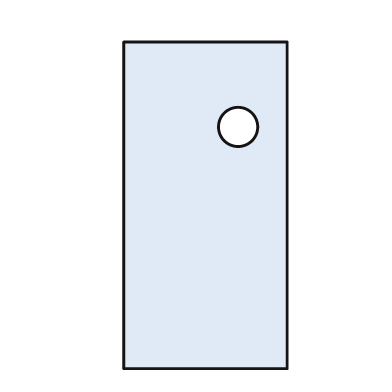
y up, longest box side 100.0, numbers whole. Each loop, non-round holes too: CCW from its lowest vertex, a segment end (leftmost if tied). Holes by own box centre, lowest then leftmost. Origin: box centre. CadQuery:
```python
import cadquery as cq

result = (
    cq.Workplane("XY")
    .moveTo(-25.0, -50.0)
    .lineTo(25.0, -50.0)
    .lineTo(25.0, 50.0)
    .lineTo(-25.0, 50.0)
    .close()
    .moveTo(10.0, 24.0)
    .circle(6.0)
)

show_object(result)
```